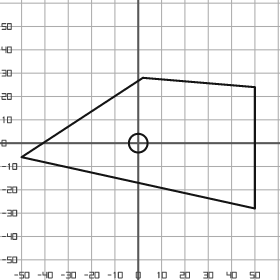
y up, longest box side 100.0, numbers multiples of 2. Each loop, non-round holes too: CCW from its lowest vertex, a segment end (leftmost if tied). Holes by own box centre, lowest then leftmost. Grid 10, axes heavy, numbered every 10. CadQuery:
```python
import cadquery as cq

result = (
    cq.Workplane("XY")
    .moveTo(50.0, -28.0)
    .lineTo(50.0, 24.0)
    .lineTo(2.0, 28.0)
    .lineTo(-50.0, -6.0)
    .close()
    .moveTo(0.0, 0.0)
    .circle(4.0)
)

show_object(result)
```